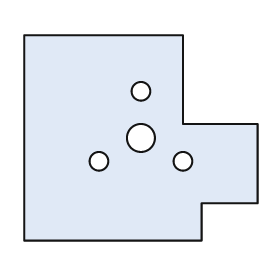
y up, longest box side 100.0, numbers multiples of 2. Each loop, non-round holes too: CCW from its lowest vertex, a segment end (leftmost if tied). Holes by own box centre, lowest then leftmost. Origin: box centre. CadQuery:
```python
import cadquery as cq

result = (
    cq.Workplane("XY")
    .moveTo(-50.0, -44.0)
    .lineTo(26.0, -44.0)
    .lineTo(26.0, -28.0)
    .lineTo(50.0, -28.0)
    .lineTo(50.0, 6.0)
    .lineTo(18.0, 6.0)
    .lineTo(18.0, 44.0)
    .lineTo(-50.0, 44.0)
    .close()
    .moveTo(-18.0, -10.0)
    .circle(4.0)
    .moveTo(18.0, -10.0)
    .circle(4.0)
    .moveTo(0.0, 0.0)
    .circle(6.0)
    .moveTo(0.0, 20.0)
    .circle(4.0)
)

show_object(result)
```